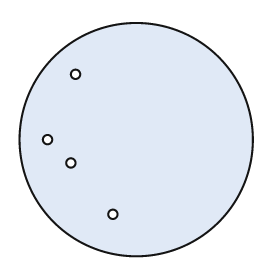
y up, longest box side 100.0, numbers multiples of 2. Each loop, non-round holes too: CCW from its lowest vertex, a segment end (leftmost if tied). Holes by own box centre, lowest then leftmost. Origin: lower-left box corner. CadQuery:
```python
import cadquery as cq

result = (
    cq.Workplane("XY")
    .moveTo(50.0, 50.0)
    .circle(50.0)
    .moveTo(40.0, 18.0)
    .circle(2.0)
    .moveTo(22.0, 40.0)
    .circle(2.0)
    .moveTo(12.0, 50.0)
    .circle(2.0)
    .moveTo(24.0, 78.0)
    .circle(2.0)
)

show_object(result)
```